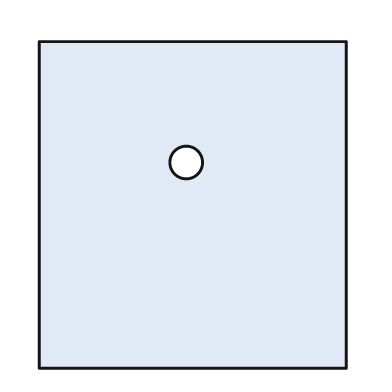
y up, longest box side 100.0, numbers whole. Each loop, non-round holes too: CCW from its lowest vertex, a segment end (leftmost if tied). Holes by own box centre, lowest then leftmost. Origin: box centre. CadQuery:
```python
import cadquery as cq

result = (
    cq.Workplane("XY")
    .moveTo(-47.0, -50.0)
    .lineTo(47.0, -50.0)
    .lineTo(47.0, 50.0)
    .lineTo(-47.0, 50.0)
    .close()
    .moveTo(-2.0, 13.0)
    .circle(5.0)
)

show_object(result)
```